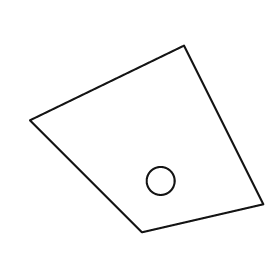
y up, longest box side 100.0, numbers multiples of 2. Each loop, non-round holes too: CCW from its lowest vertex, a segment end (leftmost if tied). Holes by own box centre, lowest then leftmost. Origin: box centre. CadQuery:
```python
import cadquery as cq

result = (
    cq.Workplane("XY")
    .moveTo(-2.0, -40.0)
    .lineTo(50.0, -28.0)
    .lineTo(16.0, 40.0)
    .lineTo(-50.0, 8.0)
    .close()
    .moveTo(6.0, -18.0)
    .circle(6.0)
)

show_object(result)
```